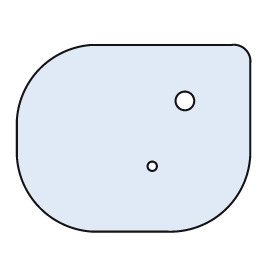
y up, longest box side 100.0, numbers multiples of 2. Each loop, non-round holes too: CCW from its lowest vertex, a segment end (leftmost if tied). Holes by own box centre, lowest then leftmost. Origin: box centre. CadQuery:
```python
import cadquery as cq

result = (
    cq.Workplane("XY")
    .moveTo(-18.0, -40.0)
    .lineTo(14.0, -40.0)
    .threePointArc((40.0, -30.0), (50.0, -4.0))
    .lineTo(50.0, 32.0)
    .threePointArc((48.0, 38.0), (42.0, 40.0))
    .lineTo(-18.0, 40.0)
    .threePointArc((-40.0, 30.0), (-50.0, 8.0))
    .lineTo(-50.0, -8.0)
    .threePointArc((-40.0, -30.0), (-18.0, -40.0))
    .close()
    .moveTo(8.0, -12.0)
    .circle(2.0)
    .moveTo(22.0, 16.0)
    .circle(4.0)
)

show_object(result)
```